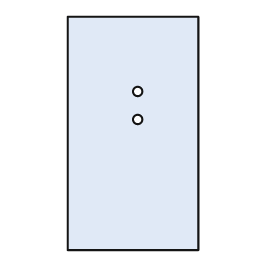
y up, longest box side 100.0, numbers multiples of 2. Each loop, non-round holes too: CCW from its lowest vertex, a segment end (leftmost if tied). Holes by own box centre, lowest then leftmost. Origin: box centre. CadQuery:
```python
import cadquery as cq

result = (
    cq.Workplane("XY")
    .moveTo(-28.0, -50.0)
    .lineTo(28.0, -50.0)
    .lineTo(28.0, 50.0)
    .lineTo(-28.0, 50.0)
    .close()
    .moveTo(2.0, 6.0)
    .circle(2.0)
    .moveTo(2.0, 18.0)
    .circle(2.0)
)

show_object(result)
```